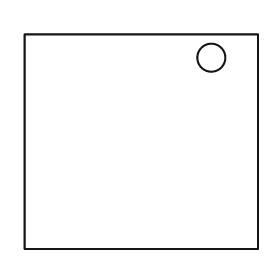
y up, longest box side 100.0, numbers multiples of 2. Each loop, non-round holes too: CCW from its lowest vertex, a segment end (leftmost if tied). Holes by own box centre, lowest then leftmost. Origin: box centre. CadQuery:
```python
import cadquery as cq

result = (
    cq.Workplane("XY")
    .moveTo(-50.0, -46.0)
    .lineTo(50.0, -46.0)
    .lineTo(50.0, 46.0)
    .lineTo(-50.0, 46.0)
    .close()
    .moveTo(30.0, 36.0)
    .circle(6.0)
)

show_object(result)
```